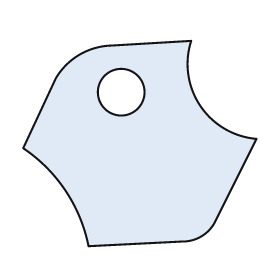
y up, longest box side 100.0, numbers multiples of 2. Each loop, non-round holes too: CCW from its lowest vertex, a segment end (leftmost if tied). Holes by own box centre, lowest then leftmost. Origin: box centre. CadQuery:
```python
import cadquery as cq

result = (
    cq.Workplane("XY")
    .moveTo(-22.0, -44.0)
    .lineTo(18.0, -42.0)
    .threePointArc((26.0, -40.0), (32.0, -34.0))
    .lineTo(50.0, 2.0)
    .threePointArc((26.0, 16.0), (22.0, 44.0))
    .lineTo(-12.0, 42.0)
    .threePointArc((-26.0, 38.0), (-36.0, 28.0))
    .lineTo(-50.0, -2.0)
    .threePointArc((-32.0, -20.0), (-22.0, -44.0))
    .close()
    .moveTo(-8.0, 22.0)
    .circle(10.0)
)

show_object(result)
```